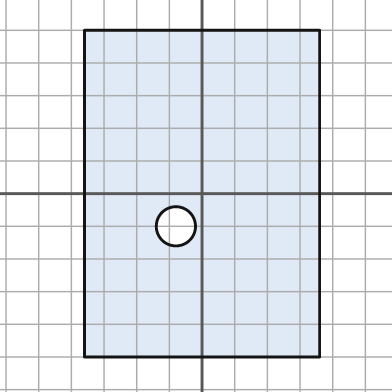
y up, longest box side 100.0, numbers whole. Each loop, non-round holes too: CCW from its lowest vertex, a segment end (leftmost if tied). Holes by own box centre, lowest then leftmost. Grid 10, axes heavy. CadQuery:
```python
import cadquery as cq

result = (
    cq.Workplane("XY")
    .moveTo(-36.0, -50.0)
    .lineTo(36.0, -50.0)
    .lineTo(36.0, 50.0)
    .lineTo(-36.0, 50.0)
    .close()
    .moveTo(-8.0, -10.0)
    .circle(6.0)
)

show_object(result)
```